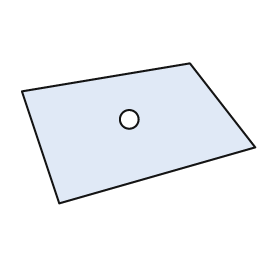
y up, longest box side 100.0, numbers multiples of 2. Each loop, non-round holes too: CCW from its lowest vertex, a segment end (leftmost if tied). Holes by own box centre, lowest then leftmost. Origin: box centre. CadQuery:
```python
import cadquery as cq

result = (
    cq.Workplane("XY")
    .moveTo(-34.0, -30.0)
    .lineTo(50.0, -6.0)
    .lineTo(22.0, 30.0)
    .lineTo(-50.0, 18.0)
    .close()
    .moveTo(-4.0, 6.0)
    .circle(4.0)
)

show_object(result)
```